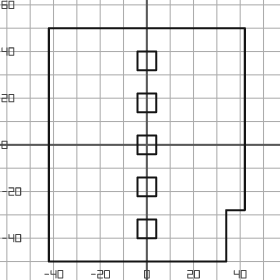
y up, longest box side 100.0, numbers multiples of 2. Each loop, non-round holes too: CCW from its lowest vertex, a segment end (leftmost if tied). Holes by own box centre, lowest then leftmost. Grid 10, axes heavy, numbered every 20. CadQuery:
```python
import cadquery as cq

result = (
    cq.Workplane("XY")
    .moveTo(-42.0, -50.0)
    .lineTo(34.0, -50.0)
    .lineTo(34.0, -28.0)
    .lineTo(42.0, -28.0)
    .lineTo(42.0, 50.0)
    .lineTo(-42.0, 50.0)
    .close()
    .moveTo(-4.0, -40.0)
    .lineTo(4.0, -40.0)
    .lineTo(4.0, -32.0)
    .lineTo(-4.0, -32.0)
    .close()
    .moveTo(-4.0, -22.0)
    .lineTo(4.0, -22.0)
    .lineTo(4.0, -14.0)
    .lineTo(-4.0, -14.0)
    .close()
    .moveTo(-4.0, -4.0)
    .lineTo(4.0, -4.0)
    .lineTo(4.0, 4.0)
    .lineTo(-4.0, 4.0)
    .close()
    .moveTo(-4.0, 14.0)
    .lineTo(4.0, 14.0)
    .lineTo(4.0, 22.0)
    .lineTo(-4.0, 22.0)
    .close()
    .moveTo(-4.0, 32.0)
    .lineTo(4.0, 32.0)
    .lineTo(4.0, 40.0)
    .lineTo(-4.0, 40.0)
    .close()
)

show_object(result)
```